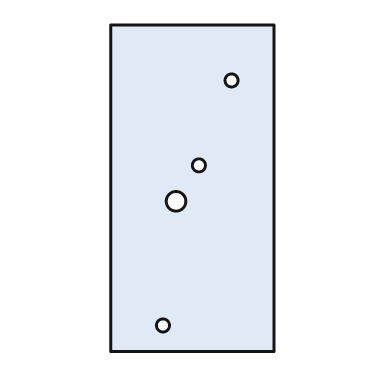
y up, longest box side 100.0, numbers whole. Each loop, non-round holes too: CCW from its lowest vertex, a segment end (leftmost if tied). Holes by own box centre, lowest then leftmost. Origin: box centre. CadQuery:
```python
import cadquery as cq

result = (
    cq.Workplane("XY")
    .moveTo(-25.0, -50.0)
    .lineTo(25.0, -50.0)
    .lineTo(25.0, 50.0)
    .lineTo(-25.0, 50.0)
    .close()
    .moveTo(-9.0, -42.0)
    .circle(2.0)
    .moveTo(-5.0, -4.0)
    .circle(3.0)
    .moveTo(2.0, 7.0)
    .circle(2.0)
    .moveTo(12.0, 33.0)
    .circle(2.0)
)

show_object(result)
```